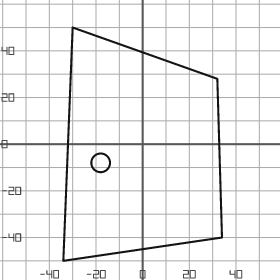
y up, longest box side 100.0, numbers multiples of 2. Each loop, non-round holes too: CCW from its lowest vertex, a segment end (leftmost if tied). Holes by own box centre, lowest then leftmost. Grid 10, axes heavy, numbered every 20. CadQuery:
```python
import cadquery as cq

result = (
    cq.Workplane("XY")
    .moveTo(-34.0, -50.0)
    .lineTo(34.0, -40.0)
    .lineTo(32.0, 28.0)
    .lineTo(-30.0, 50.0)
    .close()
    .moveTo(-18.0, -8.0)
    .circle(4.0)
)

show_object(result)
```